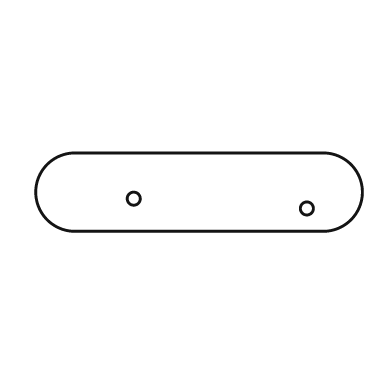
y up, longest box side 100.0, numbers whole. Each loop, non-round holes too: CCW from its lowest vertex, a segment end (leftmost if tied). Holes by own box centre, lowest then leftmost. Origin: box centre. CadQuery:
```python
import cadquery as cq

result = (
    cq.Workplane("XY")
    .moveTo(-38.0, -12.0)
    .lineTo(38.0, -12.0)
    .threePointArc((50.0, 0.0), (38.0, 12.0))
    .lineTo(-38.0, 12.0)
    .threePointArc((-50.0, 0.0), (-38.0, -12.0))
    .close()
    .moveTo(33.0, -5.0)
    .circle(2.0)
    .moveTo(-20.0, -2.0)
    .circle(2.0)
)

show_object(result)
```